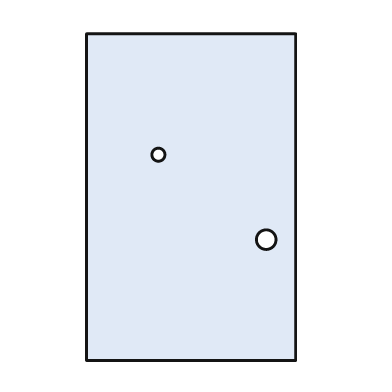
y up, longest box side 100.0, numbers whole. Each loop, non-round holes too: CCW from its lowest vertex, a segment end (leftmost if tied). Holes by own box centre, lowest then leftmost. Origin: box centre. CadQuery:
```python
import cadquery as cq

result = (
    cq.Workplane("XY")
    .moveTo(-32.0, -50.0)
    .lineTo(32.0, -50.0)
    .lineTo(32.0, 50.0)
    .lineTo(-32.0, 50.0)
    .close()
    .moveTo(23.0, -13.0)
    .circle(3.0)
    .moveTo(-10.0, 13.0)
    .circle(2.0)
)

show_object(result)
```